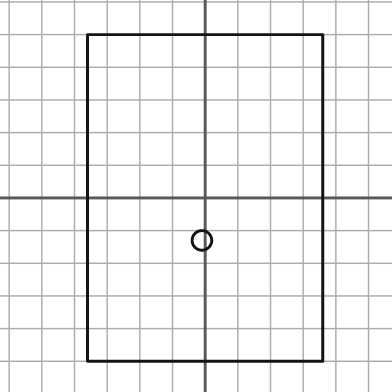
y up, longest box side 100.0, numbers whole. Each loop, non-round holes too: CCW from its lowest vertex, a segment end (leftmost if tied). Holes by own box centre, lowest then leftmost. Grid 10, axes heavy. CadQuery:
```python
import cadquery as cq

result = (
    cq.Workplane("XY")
    .moveTo(-36.0, -50.0)
    .lineTo(36.0, -50.0)
    .lineTo(36.0, 50.0)
    .lineTo(-36.0, 50.0)
    .close()
    .moveTo(-1.0, -13.0)
    .circle(3.0)
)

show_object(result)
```